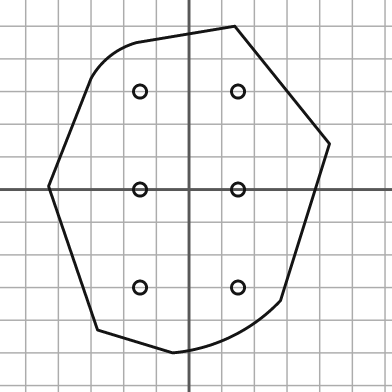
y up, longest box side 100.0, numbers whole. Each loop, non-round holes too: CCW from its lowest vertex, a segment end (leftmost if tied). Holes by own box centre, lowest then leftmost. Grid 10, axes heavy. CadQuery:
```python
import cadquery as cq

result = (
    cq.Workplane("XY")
    .moveTo(-5.0, -50.0)
    .threePointArc((13.0, -45.0), (28.0, -34.0))
    .lineTo(43.0, 14.0)
    .lineTo(14.0, 50.0)
    .lineTo(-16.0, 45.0)
    .threePointArc((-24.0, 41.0), (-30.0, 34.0))
    .lineTo(-43.0, 1.0)
    .lineTo(-28.0, -43.0)
    .close()
    .moveTo(-15.0, -30.0)
    .circle(2.0)
    .moveTo(15.0, -30.0)
    .circle(2.0)
    .moveTo(-15.0, 0.0)
    .circle(2.0)
    .moveTo(15.0, 0.0)
    .circle(2.0)
    .moveTo(-15.0, 30.0)
    .circle(2.0)
    .moveTo(15.0, 30.0)
    .circle(2.0)
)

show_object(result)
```